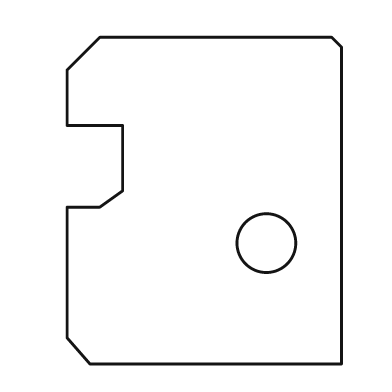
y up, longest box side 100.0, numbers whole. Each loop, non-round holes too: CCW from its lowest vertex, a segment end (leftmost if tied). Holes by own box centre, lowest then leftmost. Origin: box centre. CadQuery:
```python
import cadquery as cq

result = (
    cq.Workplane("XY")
    .moveTo(-35.0, -50.0)
    .lineTo(42.0, -50.0)
    .lineTo(42.0, 47.0)
    .lineTo(39.0, 50.0)
    .lineTo(-32.0, 50.0)
    .lineTo(-42.0, 40.0)
    .lineTo(-42.0, 23.0)
    .lineTo(-25.0, 23.0)
    .lineTo(-25.0, 3.0)
    .lineTo(-32.0, -2.0)
    .lineTo(-42.0, -2.0)
    .lineTo(-42.0, -42.0)
    .close()
    .moveTo(19.0, -13.0)
    .circle(9.0)
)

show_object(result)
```